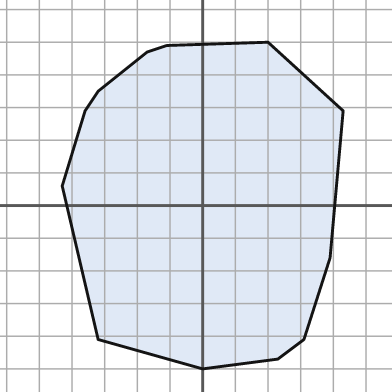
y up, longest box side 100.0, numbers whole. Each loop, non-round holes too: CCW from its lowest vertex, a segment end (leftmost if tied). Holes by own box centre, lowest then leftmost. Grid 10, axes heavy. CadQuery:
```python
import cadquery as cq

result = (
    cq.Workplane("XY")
    .moveTo(0.0, -50.0)
    .lineTo(23.0, -47.0)
    .lineTo(31.0, -41.0)
    .lineTo(39.0, -16.0)
    .lineTo(43.0, 29.0)
    .lineTo(20.0, 50.0)
    .lineTo(-11.0, 49.0)
    .lineTo(-17.0, 47.0)
    .lineTo(-32.0, 35.0)
    .lineTo(-36.0, 29.0)
    .lineTo(-43.0, 6.0)
    .lineTo(-32.0, -41.0)
    .close()
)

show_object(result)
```